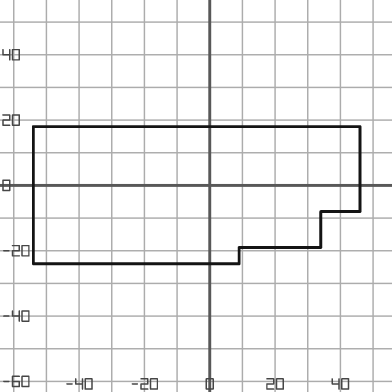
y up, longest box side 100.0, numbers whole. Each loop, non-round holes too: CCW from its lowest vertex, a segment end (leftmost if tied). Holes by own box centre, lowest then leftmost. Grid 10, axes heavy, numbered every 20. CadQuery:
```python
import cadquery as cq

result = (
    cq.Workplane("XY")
    .moveTo(-54.0, -24.0)
    .lineTo(9.0, -24.0)
    .lineTo(9.0, -19.0)
    .lineTo(34.0, -19.0)
    .lineTo(34.0, -8.0)
    .lineTo(46.0, -8.0)
    .lineTo(46.0, 18.0)
    .lineTo(-54.0, 18.0)
    .close()
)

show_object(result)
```